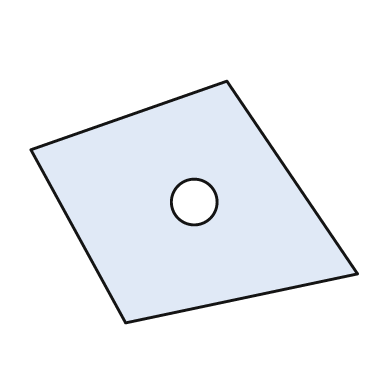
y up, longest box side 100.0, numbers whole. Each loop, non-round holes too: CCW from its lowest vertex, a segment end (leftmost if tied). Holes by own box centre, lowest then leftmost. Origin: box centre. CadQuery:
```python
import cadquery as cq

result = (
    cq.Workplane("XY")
    .moveTo(-21.0, -37.0)
    .lineTo(50.0, -22.0)
    .lineTo(10.0, 37.0)
    .lineTo(-50.0, 16.0)
    .close()
    .moveTo(0.0, 0.0)
    .circle(7.0)
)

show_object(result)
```